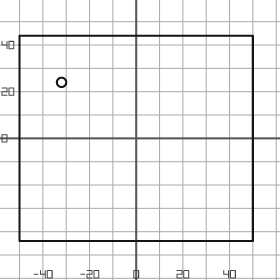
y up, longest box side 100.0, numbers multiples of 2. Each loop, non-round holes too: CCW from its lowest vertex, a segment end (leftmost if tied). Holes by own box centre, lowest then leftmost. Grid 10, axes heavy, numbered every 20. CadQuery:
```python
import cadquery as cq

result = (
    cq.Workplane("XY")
    .moveTo(-50.0, -44.0)
    .lineTo(50.0, -44.0)
    .lineTo(50.0, 44.0)
    .lineTo(-50.0, 44.0)
    .close()
    .moveTo(-32.0, 24.0)
    .circle(2.0)
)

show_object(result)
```